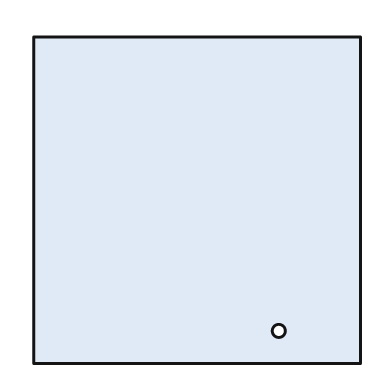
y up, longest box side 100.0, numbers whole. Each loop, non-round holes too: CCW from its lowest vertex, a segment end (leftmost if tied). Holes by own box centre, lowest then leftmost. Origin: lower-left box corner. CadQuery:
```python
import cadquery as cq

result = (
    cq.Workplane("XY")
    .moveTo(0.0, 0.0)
    .lineTo(100.0, 0.0)
    .lineTo(100.0, 100.0)
    .lineTo(0.0, 100.0)
    .close()
    .moveTo(75.0, 10.0)
    .circle(2.0)
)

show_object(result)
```